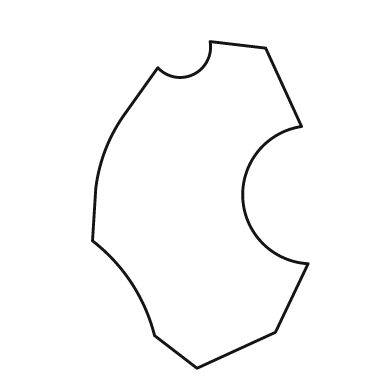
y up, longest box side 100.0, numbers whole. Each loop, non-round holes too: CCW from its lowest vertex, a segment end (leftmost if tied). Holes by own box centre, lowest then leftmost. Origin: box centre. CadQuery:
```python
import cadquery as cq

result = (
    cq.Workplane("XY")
    .moveTo(-1.0, -50.0)
    .lineTo(23.0, -39.0)
    .lineTo(33.0, -18.0)
    .threePointArc((13.0, 2.0), (31.0, 24.0))
    .lineTo(20.0, 48.0)
    .lineTo(3.0, 50.0)
    .threePointArc((-2.0, 40.0), (-13.0, 42.0))
    .lineTo(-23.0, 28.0)
    .threePointArc((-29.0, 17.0), (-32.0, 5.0))
    .lineTo(-33.0, -11.0)
    .threePointArc((-21.0, -24.0), (-14.0, -40.0))
    .close()
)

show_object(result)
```